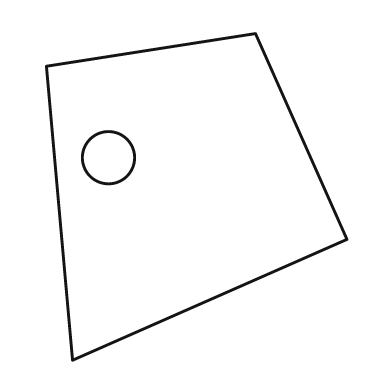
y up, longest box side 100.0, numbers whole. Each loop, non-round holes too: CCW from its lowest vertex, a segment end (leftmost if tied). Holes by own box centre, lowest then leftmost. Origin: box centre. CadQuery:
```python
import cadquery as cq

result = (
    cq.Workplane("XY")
    .moveTo(-38.0, -50.0)
    .lineTo(46.0, -13.0)
    .lineTo(18.0, 50.0)
    .lineTo(-46.0, 40.0)
    .close()
    .moveTo(-27.0, 12.0)
    .circle(8.0)
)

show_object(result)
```